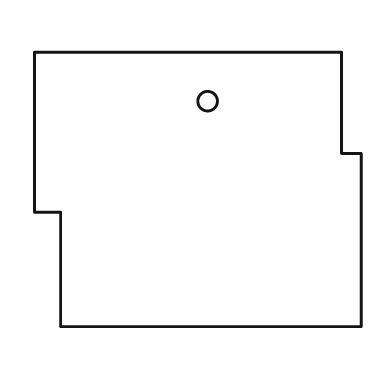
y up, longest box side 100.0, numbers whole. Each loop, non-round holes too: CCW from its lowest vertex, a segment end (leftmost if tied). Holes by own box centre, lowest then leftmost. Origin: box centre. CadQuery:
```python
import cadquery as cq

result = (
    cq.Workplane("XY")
    .moveTo(-42.0, -42.0)
    .lineTo(50.0, -42.0)
    .lineTo(50.0, 11.0)
    .lineTo(44.0, 11.0)
    .lineTo(44.0, 42.0)
    .lineTo(-50.0, 42.0)
    .lineTo(-50.0, -7.0)
    .lineTo(-42.0, -7.0)
    .close()
    .moveTo(3.0, 27.0)
    .circle(3.0)
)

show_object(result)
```